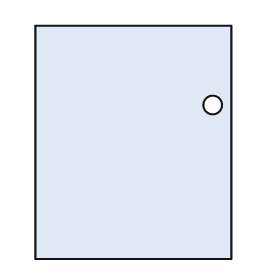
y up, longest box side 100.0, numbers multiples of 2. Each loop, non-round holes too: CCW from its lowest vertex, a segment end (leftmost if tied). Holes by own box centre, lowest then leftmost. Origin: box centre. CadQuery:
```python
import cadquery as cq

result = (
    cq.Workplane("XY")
    .moveTo(-42.0, -50.0)
    .lineTo(42.0, -50.0)
    .lineTo(42.0, 50.0)
    .lineTo(-42.0, 50.0)
    .close()
    .moveTo(34.0, 16.0)
    .circle(4.0)
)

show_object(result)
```